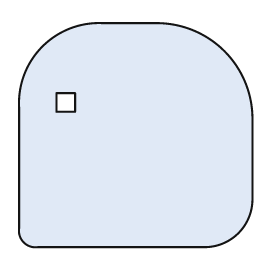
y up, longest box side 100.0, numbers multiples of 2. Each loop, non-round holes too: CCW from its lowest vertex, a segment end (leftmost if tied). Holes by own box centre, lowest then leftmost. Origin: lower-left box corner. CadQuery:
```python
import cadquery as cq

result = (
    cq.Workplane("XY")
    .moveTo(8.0, 0.0)
    .lineTo(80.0, 0.0)
    .threePointArc((94.0, 6.0), (100.0, 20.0))
    .lineTo(100.0, 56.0)
    .threePointArc((88.0, 84.0), (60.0, 96.0))
    .lineTo(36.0, 96.0)
    .threePointArc((10.0, 86.0), (0.0, 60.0))
    .lineTo(0.0, 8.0)
    .threePointArc((2.0, 2.0), (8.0, 0.0))
    .close()
    .moveTo(16.0, 58.0)
    .lineTo(24.0, 58.0)
    .lineTo(24.0, 66.0)
    .lineTo(16.0, 66.0)
    .close()
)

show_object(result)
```